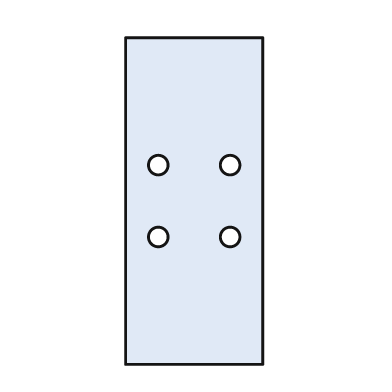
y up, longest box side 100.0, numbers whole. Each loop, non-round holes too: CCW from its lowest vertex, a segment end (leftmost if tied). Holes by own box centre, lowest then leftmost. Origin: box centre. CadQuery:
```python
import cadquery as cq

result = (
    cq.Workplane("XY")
    .moveTo(-21.0, -50.0)
    .lineTo(21.0, -50.0)
    .lineTo(21.0, 50.0)
    .lineTo(-21.0, 50.0)
    .close()
    .moveTo(-11.0, -11.0)
    .circle(3.0)
    .moveTo(11.0, -11.0)
    .circle(3.0)
    .moveTo(-11.0, 11.0)
    .circle(3.0)
    .moveTo(11.0, 11.0)
    .circle(3.0)
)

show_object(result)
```